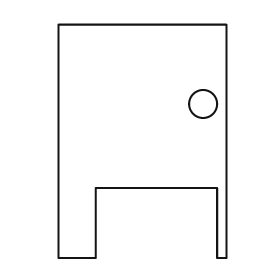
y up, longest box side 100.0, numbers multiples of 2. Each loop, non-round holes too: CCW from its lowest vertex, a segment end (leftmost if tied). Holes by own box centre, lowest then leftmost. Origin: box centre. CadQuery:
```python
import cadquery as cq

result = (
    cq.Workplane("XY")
    .moveTo(-36.0, -50.0)
    .lineTo(-20.0, -50.0)
    .lineTo(-20.0, -20.0)
    .lineTo(32.0, -20.0)
    .lineTo(32.0, -50.0)
    .lineTo(36.0, -50.0)
    .lineTo(36.0, 50.0)
    .lineTo(-36.0, 50.0)
    .close()
    .moveTo(26.0, 16.0)
    .circle(6.0)
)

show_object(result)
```